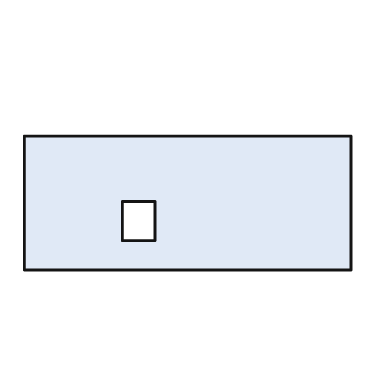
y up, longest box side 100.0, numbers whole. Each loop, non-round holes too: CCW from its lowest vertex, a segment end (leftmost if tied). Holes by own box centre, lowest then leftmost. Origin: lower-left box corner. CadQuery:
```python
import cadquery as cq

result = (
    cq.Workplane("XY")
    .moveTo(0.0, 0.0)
    .lineTo(100.0, 0.0)
    .lineTo(100.0, 41.0)
    .lineTo(0.0, 41.0)
    .close()
    .moveTo(30.0, 9.0)
    .lineTo(40.0, 9.0)
    .lineTo(40.0, 21.0)
    .lineTo(30.0, 21.0)
    .close()
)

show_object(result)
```